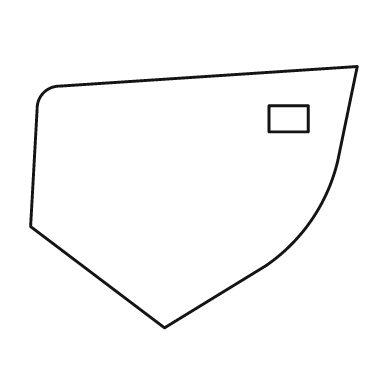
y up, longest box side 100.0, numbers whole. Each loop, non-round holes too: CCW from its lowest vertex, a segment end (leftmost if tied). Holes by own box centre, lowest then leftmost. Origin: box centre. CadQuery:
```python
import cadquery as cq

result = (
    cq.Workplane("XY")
    .moveTo(-9.0, -40.0)
    .lineTo(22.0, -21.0)
    .threePointArc((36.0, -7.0), (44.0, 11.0))
    .lineTo(50.0, 40.0)
    .lineTo(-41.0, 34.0)
    .threePointArc((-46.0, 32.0), (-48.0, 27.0))
    .lineTo(-50.0, -9.0)
    .close()
    .moveTo(23.0, 20.0)
    .lineTo(35.0, 20.0)
    .lineTo(35.0, 28.0)
    .lineTo(23.0, 28.0)
    .close()
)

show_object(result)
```